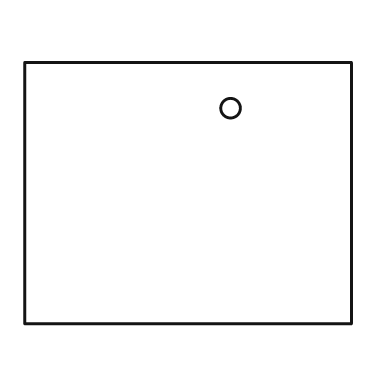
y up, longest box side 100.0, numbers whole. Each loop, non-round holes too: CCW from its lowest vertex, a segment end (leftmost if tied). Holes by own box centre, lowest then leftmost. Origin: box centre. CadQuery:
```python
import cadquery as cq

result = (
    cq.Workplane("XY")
    .moveTo(-50.0, -40.0)
    .lineTo(50.0, -40.0)
    .lineTo(50.0, 40.0)
    .lineTo(-50.0, 40.0)
    .close()
    .moveTo(13.0, 26.0)
    .circle(3.0)
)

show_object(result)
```